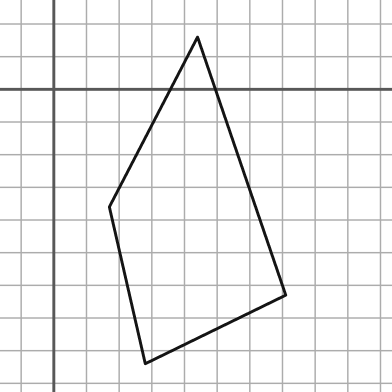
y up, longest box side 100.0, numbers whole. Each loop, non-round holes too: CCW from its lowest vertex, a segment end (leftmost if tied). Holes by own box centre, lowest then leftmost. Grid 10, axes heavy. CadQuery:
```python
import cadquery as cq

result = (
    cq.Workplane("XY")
    .moveTo(28.0, -84.0)
    .lineTo(71.0, -63.0)
    .lineTo(44.0, 16.0)
    .lineTo(17.0, -36.0)
    .close()
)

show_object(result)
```